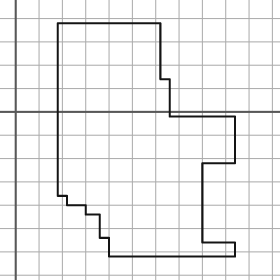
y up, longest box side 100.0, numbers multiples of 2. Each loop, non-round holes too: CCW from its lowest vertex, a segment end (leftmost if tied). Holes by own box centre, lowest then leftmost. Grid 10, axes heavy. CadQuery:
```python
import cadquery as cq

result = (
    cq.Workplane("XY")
    .moveTo(40.0, -62.0)
    .lineTo(94.0, -62.0)
    .lineTo(94.0, -56.0)
    .lineTo(80.0, -56.0)
    .lineTo(80.0, -22.0)
    .lineTo(94.0, -22.0)
    .lineTo(94.0, -2.0)
    .lineTo(66.0, -2.0)
    .lineTo(66.0, 14.0)
    .lineTo(62.0, 14.0)
    .lineTo(62.0, 38.0)
    .lineTo(18.0, 38.0)
    .lineTo(18.0, -36.0)
    .lineTo(22.0, -36.0)
    .lineTo(22.0, -40.0)
    .lineTo(30.0, -40.0)
    .lineTo(30.0, -44.0)
    .lineTo(36.0, -44.0)
    .lineTo(36.0, -54.0)
    .lineTo(40.0, -54.0)
    .close()
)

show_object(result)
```